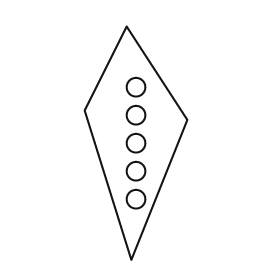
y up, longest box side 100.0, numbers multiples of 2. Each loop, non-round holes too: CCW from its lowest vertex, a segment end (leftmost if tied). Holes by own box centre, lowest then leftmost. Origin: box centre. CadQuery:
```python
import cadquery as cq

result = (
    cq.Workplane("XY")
    .moveTo(-2.0, -50.0)
    .lineTo(22.0, 10.0)
    .lineTo(-4.0, 50.0)
    .lineTo(-22.0, 14.0)
    .close()
    .moveTo(0.0, -24.0)
    .circle(4.0)
    .moveTo(0.0, -12.0)
    .circle(4.0)
    .moveTo(0.0, 0.0)
    .circle(4.0)
    .moveTo(0.0, 12.0)
    .circle(4.0)
    .moveTo(0.0, 24.0)
    .circle(4.0)
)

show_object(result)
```